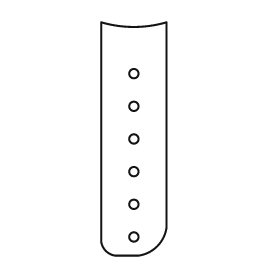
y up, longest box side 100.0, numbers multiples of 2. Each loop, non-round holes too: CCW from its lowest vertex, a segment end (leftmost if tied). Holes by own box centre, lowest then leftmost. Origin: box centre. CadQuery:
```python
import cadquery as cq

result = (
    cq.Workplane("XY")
    .moveTo(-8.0, -50.0)
    .lineTo(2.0, -50.0)
    .threePointArc((10.0, -46.0), (14.0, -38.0))
    .lineTo(14.0, 50.0)
    .threePointArc((0.0, 48.0), (-14.0, 50.0))
    .lineTo(-14.0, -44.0)
    .threePointArc((-12.0, -48.0), (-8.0, -50.0))
    .close()
    .moveTo(0.0, -42.0)
    .circle(2.0)
    .moveTo(0.0, -28.0)
    .circle(2.0)
    .moveTo(0.0, -14.0)
    .circle(2.0)
    .moveTo(0.0, 0.0)
    .circle(2.0)
    .moveTo(0.0, 14.0)
    .circle(2.0)
    .moveTo(0.0, 28.0)
    .circle(2.0)
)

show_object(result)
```